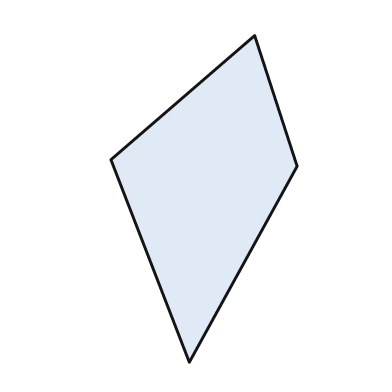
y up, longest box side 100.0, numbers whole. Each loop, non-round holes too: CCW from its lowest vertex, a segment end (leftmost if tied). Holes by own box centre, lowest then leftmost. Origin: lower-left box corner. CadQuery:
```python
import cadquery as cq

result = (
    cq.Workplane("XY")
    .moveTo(24.0, 0.0)
    .lineTo(57.0, 60.0)
    .lineTo(44.0, 100.0)
    .lineTo(0.0, 62.0)
    .close()
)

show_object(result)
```